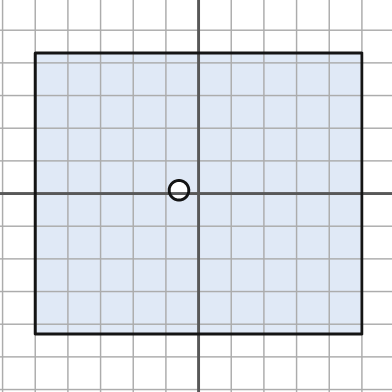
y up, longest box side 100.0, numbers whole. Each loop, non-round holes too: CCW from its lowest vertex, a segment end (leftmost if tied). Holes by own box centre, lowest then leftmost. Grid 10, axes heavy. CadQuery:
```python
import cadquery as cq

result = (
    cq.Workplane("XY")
    .moveTo(-50.0, -43.0)
    .lineTo(50.0, -43.0)
    .lineTo(50.0, 43.0)
    .lineTo(-50.0, 43.0)
    .close()
    .moveTo(-6.0, 1.0)
    .circle(3.0)
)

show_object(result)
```